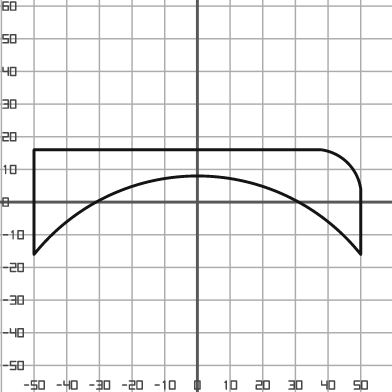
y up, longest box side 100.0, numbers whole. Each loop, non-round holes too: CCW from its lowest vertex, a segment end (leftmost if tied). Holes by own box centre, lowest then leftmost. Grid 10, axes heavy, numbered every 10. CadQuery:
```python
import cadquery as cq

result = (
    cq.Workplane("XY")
    .moveTo(-50.0, -16.0)
    .threePointArc((0.0, 8.0), (50.0, -16.0))
    .lineTo(50.0, 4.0)
    .threePointArc((46.0, 12.0), (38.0, 16.0))
    .lineTo(-50.0, 16.0)
    .close()
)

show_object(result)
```